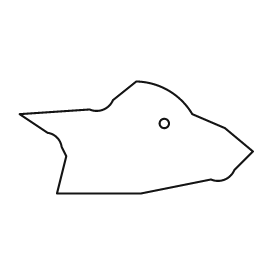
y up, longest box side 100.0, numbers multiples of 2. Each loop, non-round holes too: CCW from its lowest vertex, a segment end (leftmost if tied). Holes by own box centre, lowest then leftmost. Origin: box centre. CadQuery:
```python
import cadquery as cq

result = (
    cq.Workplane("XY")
    .moveTo(-34.0, -24.0)
    .lineTo(2.0, -24.0)
    .lineTo(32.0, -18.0)
    .threePointArc((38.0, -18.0), (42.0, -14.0))
    .lineTo(50.0, -6.0)
    .lineTo(38.0, 4.0)
    .lineTo(24.0, 10.0)
    .threePointArc((14.0, 20.0), (0.0, 24.0))
    .lineTo(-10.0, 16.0)
    .threePointArc((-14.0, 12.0), (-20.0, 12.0))
    .lineTo(-50.0, 10.0)
    .lineTo(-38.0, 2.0)
    .threePointArc((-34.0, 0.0), (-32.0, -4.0))
    .lineTo(-30.0, -8.0)
    .close()
    .moveTo(12.0, 6.0)
    .circle(2.0)
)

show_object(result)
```